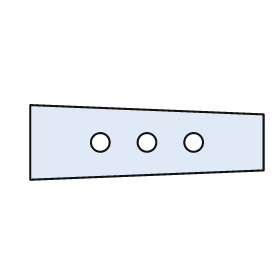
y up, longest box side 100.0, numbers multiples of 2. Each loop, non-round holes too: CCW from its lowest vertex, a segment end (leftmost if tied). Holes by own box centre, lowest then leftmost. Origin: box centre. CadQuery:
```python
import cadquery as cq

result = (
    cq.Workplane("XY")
    .moveTo(-50.0, -16.0)
    .lineTo(50.0, -12.0)
    .lineTo(50.0, 12.0)
    .lineTo(-50.0, 16.0)
    .close()
    .moveTo(-20.0, 0.0)
    .circle(4.0)
    .moveTo(0.0, 0.0)
    .circle(4.0)
    .moveTo(20.0, 0.0)
    .circle(4.0)
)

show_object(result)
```